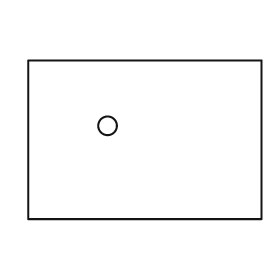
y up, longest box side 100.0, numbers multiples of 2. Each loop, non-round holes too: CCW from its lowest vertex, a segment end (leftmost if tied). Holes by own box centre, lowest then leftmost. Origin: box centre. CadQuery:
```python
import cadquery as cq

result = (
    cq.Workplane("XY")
    .moveTo(-50.0, -34.0)
    .lineTo(50.0, -34.0)
    .lineTo(50.0, 34.0)
    .lineTo(-50.0, 34.0)
    .close()
    .moveTo(-16.0, 6.0)
    .circle(4.0)
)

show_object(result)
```